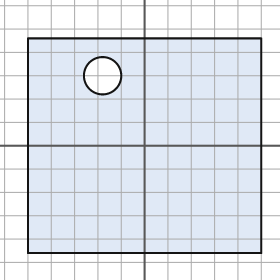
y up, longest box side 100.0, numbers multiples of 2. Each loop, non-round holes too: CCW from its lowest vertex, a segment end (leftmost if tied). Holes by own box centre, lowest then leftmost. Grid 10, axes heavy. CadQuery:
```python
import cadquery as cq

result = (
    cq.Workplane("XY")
    .moveTo(-50.0, -46.0)
    .lineTo(50.0, -46.0)
    .lineTo(50.0, 46.0)
    .lineTo(-50.0, 46.0)
    .close()
    .moveTo(-18.0, 30.0)
    .circle(8.0)
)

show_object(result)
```